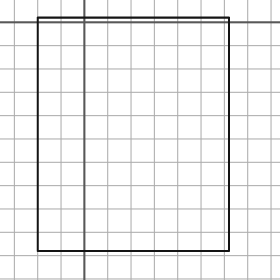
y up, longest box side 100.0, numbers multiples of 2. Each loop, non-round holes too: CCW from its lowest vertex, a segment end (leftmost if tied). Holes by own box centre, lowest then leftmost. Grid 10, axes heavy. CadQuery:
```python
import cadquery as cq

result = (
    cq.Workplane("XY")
    .moveTo(-20.0, -98.0)
    .lineTo(62.0, -98.0)
    .lineTo(62.0, 2.0)
    .lineTo(-20.0, 2.0)
    .close()
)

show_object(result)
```